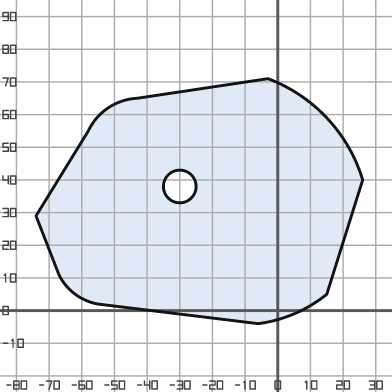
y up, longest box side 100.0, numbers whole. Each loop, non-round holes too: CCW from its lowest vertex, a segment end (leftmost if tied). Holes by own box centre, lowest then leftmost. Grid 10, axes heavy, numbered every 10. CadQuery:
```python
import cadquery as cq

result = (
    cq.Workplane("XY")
    .moveTo(-6.0, -4.0)
    .threePointArc((5.0, -1.0), (15.0, 5.0))
    .lineTo(26.0, 40.0)
    .threePointArc((15.0, 59.0), (-3.0, 71.0))
    .lineTo(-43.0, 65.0)
    .threePointArc((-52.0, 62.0), (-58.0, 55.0))
    .lineTo(-74.0, 29.0)
    .lineTo(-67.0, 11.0)
    .threePointArc((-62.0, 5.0), (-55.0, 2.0))
    .close()
    .moveTo(-30.0, 38.0)
    .circle(5.0)
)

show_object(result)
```